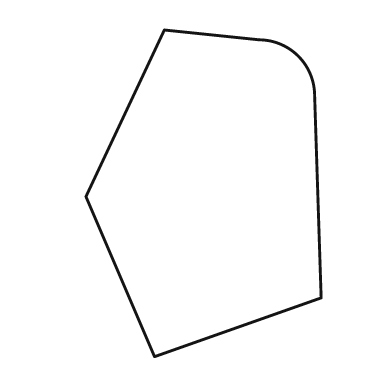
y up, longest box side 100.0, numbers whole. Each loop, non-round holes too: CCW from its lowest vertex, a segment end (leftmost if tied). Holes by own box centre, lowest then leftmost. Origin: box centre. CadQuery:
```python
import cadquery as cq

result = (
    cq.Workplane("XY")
    .moveTo(-15.0, -50.0)
    .lineTo(36.0, -32.0)
    .lineTo(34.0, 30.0)
    .threePointArc((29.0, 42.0), (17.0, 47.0))
    .lineTo(-12.0, 50.0)
    .lineTo(-36.0, -1.0)
    .close()
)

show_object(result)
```